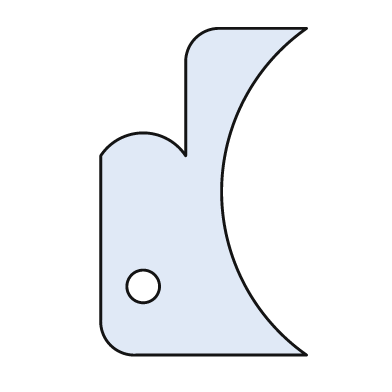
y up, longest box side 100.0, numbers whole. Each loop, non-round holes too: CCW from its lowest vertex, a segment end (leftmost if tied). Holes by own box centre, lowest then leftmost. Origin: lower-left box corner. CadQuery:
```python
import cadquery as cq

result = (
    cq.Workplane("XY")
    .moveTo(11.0, 0.0)
    .lineTo(63.0, 0.0)
    .threePointArc((37.0, 50.0), (63.0, 100.0))
    .lineTo(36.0, 100.0)
    .threePointArc((29.0, 97.0), (26.0, 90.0))
    .lineTo(26.0, 61.0)
    .threePointArc((13.0, 68.0), (0.0, 61.0))
    .lineTo(0.0, 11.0)
    .threePointArc((3.0, 3.0), (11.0, 0.0))
    .close()
    .moveTo(13.0, 21.0)
    .circle(5.0)
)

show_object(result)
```